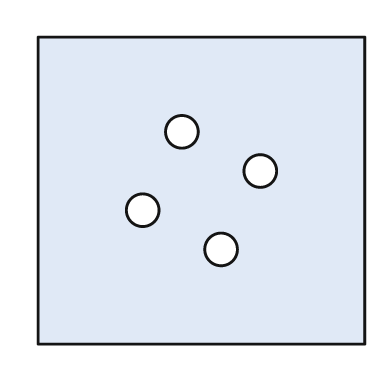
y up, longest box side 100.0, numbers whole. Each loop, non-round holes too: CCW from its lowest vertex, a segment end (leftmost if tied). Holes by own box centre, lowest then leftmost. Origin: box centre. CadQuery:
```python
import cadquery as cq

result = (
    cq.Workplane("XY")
    .moveTo(-50.0, -47.0)
    .lineTo(50.0, -47.0)
    .lineTo(50.0, 47.0)
    .lineTo(-50.0, 47.0)
    .close()
    .moveTo(6.0, -18.0)
    .circle(5.0)
    .moveTo(-18.0, -6.0)
    .circle(5.0)
    .moveTo(18.0, 6.0)
    .circle(5.0)
    .moveTo(-6.0, 18.0)
    .circle(5.0)
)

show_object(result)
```